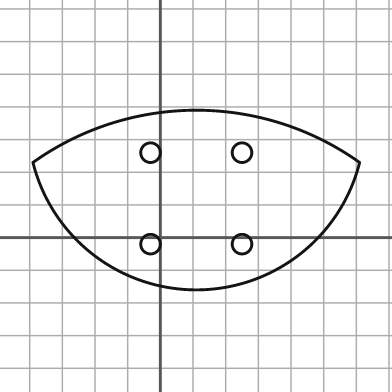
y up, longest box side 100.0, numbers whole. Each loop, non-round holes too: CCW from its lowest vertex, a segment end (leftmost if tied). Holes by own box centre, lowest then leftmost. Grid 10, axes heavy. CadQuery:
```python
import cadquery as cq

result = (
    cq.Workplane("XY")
    .moveTo(-39.0, 23.0)
    .threePointArc((11.0, -16.0), (61.0, 23.0))
    .threePointArc((11.0, 39.0), (-39.0, 23.0))
    .close()
    .moveTo(-3.0, -2.0)
    .circle(3.0)
    .moveTo(25.0, -2.0)
    .circle(3.0)
    .moveTo(-3.0, 26.0)
    .circle(3.0)
    .moveTo(25.0, 26.0)
    .circle(3.0)
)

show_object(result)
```